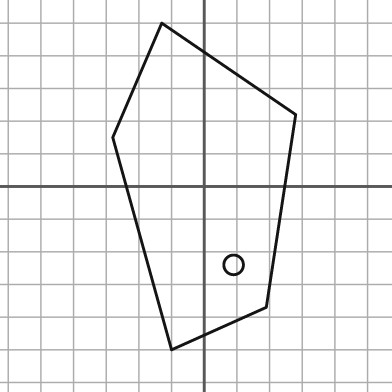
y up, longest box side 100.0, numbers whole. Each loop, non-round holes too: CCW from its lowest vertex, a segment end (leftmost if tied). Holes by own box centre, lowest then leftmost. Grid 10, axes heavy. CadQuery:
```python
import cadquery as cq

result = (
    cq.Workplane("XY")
    .moveTo(-10.0, -50.0)
    .lineTo(19.0, -37.0)
    .lineTo(28.0, 22.0)
    .lineTo(-13.0, 50.0)
    .lineTo(-28.0, 15.0)
    .close()
    .moveTo(9.0, -24.0)
    .circle(3.0)
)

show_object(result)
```